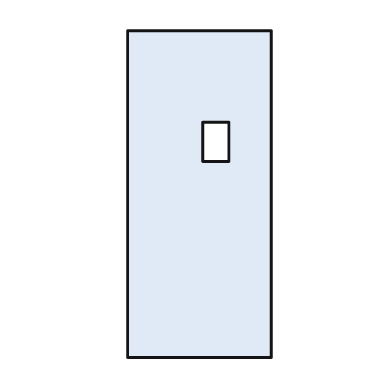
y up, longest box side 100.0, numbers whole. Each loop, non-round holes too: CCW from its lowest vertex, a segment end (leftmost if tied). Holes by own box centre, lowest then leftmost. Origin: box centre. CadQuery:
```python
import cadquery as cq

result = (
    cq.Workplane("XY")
    .moveTo(-22.0, -50.0)
    .lineTo(22.0, -50.0)
    .lineTo(22.0, 50.0)
    .lineTo(-22.0, 50.0)
    .close()
    .moveTo(1.0, 10.0)
    .lineTo(9.0, 10.0)
    .lineTo(9.0, 22.0)
    .lineTo(1.0, 22.0)
    .close()
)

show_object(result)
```